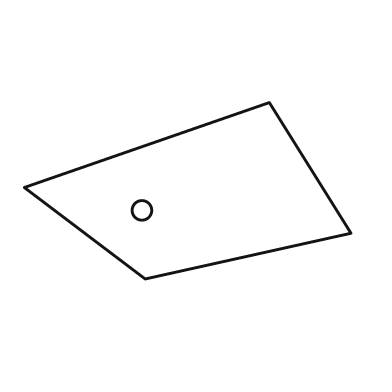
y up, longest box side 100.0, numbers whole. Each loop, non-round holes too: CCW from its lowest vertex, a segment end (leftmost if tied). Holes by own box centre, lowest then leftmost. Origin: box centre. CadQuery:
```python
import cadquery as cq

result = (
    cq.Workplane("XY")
    .moveTo(-13.0, -27.0)
    .lineTo(50.0, -13.0)
    .lineTo(25.0, 27.0)
    .lineTo(-50.0, 1.0)
    .close()
    .moveTo(-14.0, -6.0)
    .circle(3.0)
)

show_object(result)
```